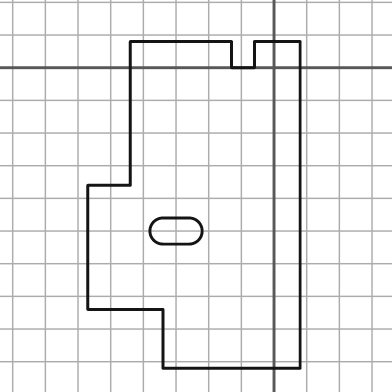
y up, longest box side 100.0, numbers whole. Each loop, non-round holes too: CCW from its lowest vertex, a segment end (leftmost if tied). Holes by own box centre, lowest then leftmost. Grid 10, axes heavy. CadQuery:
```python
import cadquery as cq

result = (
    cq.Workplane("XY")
    .moveTo(-34.0, -92.0)
    .lineTo(8.0, -92.0)
    .lineTo(8.0, 8.0)
    .lineTo(-6.0, 8.0)
    .lineTo(-6.0, 0.0)
    .lineTo(-13.0, 0.0)
    .lineTo(-13.0, 8.0)
    .lineTo(-44.0, 8.0)
    .lineTo(-44.0, -36.0)
    .lineTo(-57.0, -36.0)
    .lineTo(-57.0, -74.0)
    .lineTo(-34.0, -74.0)
    .close()
    .moveTo(-34.0, -54.0)
    .lineTo(-26.0, -54.0)
    .threePointArc((-22.0, -50.0), (-26.0, -46.0))
    .lineTo(-34.0, -46.0)
    .threePointArc((-38.0, -50.0), (-34.0, -54.0))
    .close()
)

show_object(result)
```